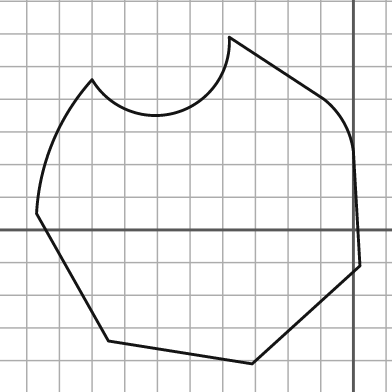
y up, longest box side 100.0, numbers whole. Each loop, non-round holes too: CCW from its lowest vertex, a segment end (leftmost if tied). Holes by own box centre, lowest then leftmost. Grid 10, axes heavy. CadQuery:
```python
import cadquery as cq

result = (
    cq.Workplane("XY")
    .moveTo(-31.0, -41.0)
    .lineTo(2.0, -11.0)
    .lineTo(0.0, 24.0)
    .threePointArc((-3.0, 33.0), (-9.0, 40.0))
    .lineTo(-38.0, 59.0)
    .threePointArc((-54.0, 36.0), (-80.0, 46.0))
    .threePointArc((-92.0, 27.0), (-97.0, 5.0))
    .lineTo(-75.0, -34.0)
    .close()
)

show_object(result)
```